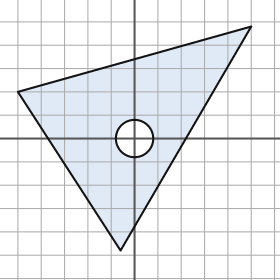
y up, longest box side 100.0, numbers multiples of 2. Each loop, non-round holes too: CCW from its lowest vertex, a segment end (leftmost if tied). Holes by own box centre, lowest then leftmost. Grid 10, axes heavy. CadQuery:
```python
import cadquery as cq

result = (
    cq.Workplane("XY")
    .moveTo(-6.0, -48.0)
    .lineTo(50.0, 48.0)
    .lineTo(-50.0, 20.0)
    .close()
    .moveTo(0.0, 0.0)
    .circle(8.0)
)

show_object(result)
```